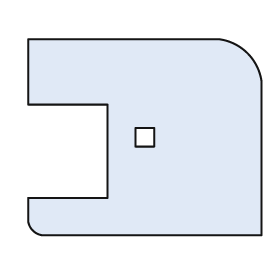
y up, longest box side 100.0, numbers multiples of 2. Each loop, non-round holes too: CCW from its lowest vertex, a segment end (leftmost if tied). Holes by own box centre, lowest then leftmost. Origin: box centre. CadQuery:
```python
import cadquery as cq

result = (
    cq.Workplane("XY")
    .moveTo(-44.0, -42.0)
    .lineTo(50.0, -42.0)
    .lineTo(50.0, 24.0)
    .threePointArc((44.0, 36.0), (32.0, 42.0))
    .lineTo(-50.0, 42.0)
    .lineTo(-50.0, 14.0)
    .lineTo(-16.0, 14.0)
    .lineTo(-16.0, -26.0)
    .lineTo(-50.0, -26.0)
    .lineTo(-50.0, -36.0)
    .threePointArc((-48.0, -40.0), (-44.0, -42.0))
    .close()
    .moveTo(-4.0, -4.0)
    .lineTo(4.0, -4.0)
    .lineTo(4.0, 4.0)
    .lineTo(-4.0, 4.0)
    .close()
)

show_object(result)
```